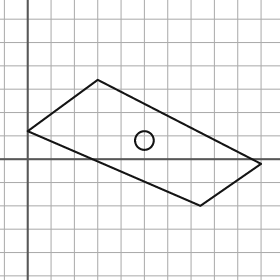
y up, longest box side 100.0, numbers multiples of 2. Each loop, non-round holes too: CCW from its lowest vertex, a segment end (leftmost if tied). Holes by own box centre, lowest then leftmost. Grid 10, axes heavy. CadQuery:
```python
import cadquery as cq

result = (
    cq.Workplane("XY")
    .moveTo(74.0, -20.0)
    .lineTo(100.0, -2.0)
    .lineTo(30.0, 34.0)
    .lineTo(0.0, 12.0)
    .close()
    .moveTo(50.0, 8.0)
    .circle(4.0)
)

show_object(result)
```